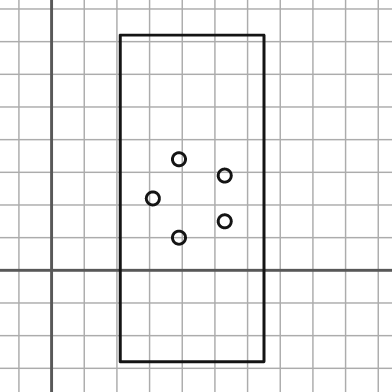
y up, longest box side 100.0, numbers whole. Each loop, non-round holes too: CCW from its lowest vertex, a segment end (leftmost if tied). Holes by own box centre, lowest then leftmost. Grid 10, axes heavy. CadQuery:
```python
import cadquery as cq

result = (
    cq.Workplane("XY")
    .moveTo(21.0, -28.0)
    .lineTo(65.0, -28.0)
    .lineTo(65.0, 72.0)
    .lineTo(21.0, 72.0)
    .close()
    .moveTo(39.0, 10.0)
    .circle(2.0)
    .moveTo(53.0, 15.0)
    .circle(2.0)
    .moveTo(31.0, 22.0)
    .circle(2.0)
    .moveTo(53.0, 29.0)
    .circle(2.0)
    .moveTo(39.0, 34.0)
    .circle(2.0)
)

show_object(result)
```